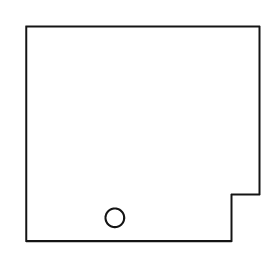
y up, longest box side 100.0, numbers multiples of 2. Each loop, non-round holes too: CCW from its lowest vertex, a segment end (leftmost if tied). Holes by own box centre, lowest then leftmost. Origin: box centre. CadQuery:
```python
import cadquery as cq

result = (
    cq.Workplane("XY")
    .moveTo(-50.0, -46.0)
    .lineTo(38.0, -46.0)
    .lineTo(38.0, -26.0)
    .lineTo(50.0, -26.0)
    .lineTo(50.0, 46.0)
    .lineTo(-50.0, 46.0)
    .close()
    .moveTo(-12.0, -36.0)
    .circle(4.0)
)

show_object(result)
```